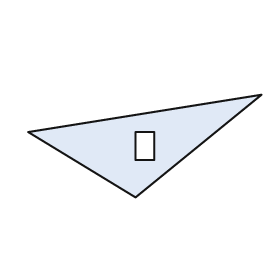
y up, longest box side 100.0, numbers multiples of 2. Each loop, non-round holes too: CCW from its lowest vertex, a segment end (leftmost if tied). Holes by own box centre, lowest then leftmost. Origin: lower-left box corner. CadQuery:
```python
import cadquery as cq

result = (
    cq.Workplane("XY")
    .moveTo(46.0, 0.0)
    .lineTo(100.0, 44.0)
    .lineTo(0.0, 28.0)
    .close()
    .moveTo(46.0, 16.0)
    .lineTo(54.0, 16.0)
    .lineTo(54.0, 28.0)
    .lineTo(46.0, 28.0)
    .close()
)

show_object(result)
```